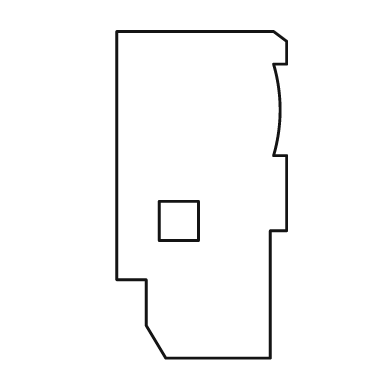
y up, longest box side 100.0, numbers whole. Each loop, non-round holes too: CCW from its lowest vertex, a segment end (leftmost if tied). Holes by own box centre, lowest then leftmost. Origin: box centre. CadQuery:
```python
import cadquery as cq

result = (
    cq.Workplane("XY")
    .moveTo(-11.0, -50.0)
    .lineTo(21.0, -50.0)
    .lineTo(21.0, -11.0)
    .lineTo(26.0, -11.0)
    .lineTo(26.0, 12.0)
    .lineTo(22.0, 12.0)
    .threePointArc((24.0, 26.0), (22.0, 40.0))
    .lineTo(26.0, 40.0)
    .lineTo(26.0, 47.0)
    .lineTo(22.0, 50.0)
    .lineTo(-26.0, 50.0)
    .lineTo(-26.0, -26.0)
    .lineTo(-17.0, -26.0)
    .lineTo(-17.0, -40.0)
    .close()
    .moveTo(-13.0, -14.0)
    .lineTo(-1.0, -14.0)
    .lineTo(-1.0, -2.0)
    .lineTo(-13.0, -2.0)
    .close()
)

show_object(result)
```